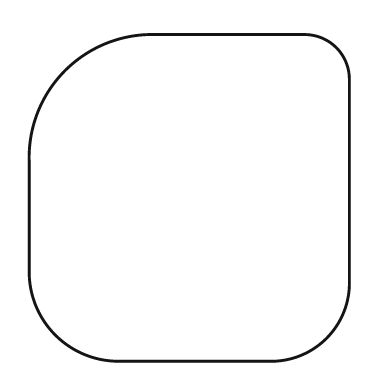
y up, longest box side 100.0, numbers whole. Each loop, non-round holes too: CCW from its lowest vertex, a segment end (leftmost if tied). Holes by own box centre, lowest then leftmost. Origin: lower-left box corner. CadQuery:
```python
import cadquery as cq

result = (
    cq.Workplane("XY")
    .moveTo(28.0, 0.0)
    .lineTo(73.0, 0.0)
    .threePointArc((91.0, 7.0), (98.0, 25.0))
    .lineTo(98.0, 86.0)
    .threePointArc((94.0, 96.0), (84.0, 100.0))
    .lineTo(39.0, 100.0)
    .threePointArc((11.0, 89.0), (0.0, 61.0))
    .lineTo(0.0, 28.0)
    .threePointArc((8.0, 8.0), (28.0, 0.0))
    .close()
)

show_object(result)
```